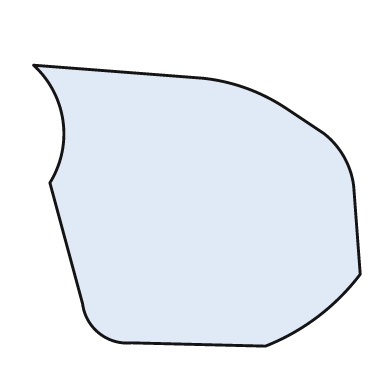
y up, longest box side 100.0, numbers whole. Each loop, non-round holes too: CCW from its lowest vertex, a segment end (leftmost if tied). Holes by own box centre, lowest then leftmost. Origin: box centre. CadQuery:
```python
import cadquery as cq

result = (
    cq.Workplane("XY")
    .moveTo(21.0, -43.0)
    .threePointArc((37.0, -34.0), (50.0, -21.0))
    .lineTo(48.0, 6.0)
    .threePointArc((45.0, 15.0), (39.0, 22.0))
    .lineTo(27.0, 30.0)
    .threePointArc((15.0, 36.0), (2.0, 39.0))
    .lineTo(-50.0, 43.0)
    .threePointArc((-41.0, 26.0), (-45.0, 7.0))
    .lineTo(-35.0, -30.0)
    .threePointArc((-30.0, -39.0), (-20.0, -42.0))
    .close()
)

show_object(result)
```